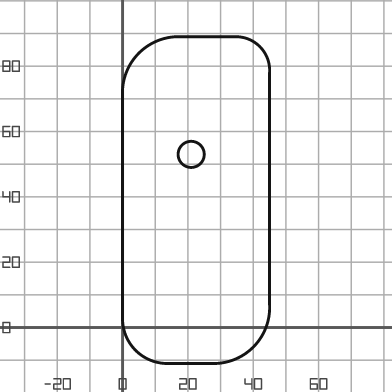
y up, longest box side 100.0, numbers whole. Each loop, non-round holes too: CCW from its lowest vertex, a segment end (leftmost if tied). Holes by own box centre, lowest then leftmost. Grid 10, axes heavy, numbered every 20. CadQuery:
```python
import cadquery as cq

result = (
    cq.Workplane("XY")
    .moveTo(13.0, -11.0)
    .lineTo(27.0, -11.0)
    .threePointArc((40.0, -6.0), (45.0, 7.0))
    .lineTo(45.0, 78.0)
    .threePointArc((42.0, 86.0), (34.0, 89.0))
    .lineTo(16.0, 89.0)
    .threePointArc((5.0, 84.0), (0.0, 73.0))
    .lineTo(0.0, 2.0)
    .threePointArc((4.0, -7.0), (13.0, -11.0))
    .close()
    .moveTo(21.0, 53.0)
    .circle(4.0)
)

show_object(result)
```